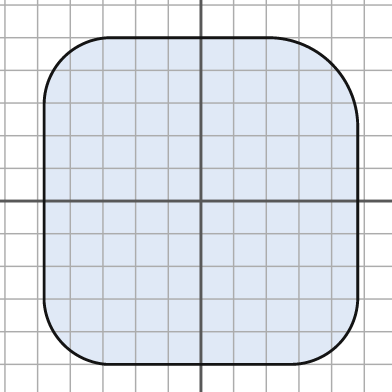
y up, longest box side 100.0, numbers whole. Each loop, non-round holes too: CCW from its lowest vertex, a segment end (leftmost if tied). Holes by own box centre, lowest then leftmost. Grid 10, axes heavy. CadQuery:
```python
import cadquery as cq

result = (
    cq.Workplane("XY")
    .moveTo(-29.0, -50.0)
    .lineTo(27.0, -50.0)
    .threePointArc((42.0, -44.0), (48.0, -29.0))
    .lineTo(48.0, 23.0)
    .threePointArc((40.0, 42.0), (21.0, 50.0))
    .lineTo(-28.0, 50.0)
    .threePointArc((-42.0, 44.0), (-48.0, 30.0))
    .lineTo(-48.0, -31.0)
    .threePointArc((-42.0, -44.0), (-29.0, -50.0))
    .close()
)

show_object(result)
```